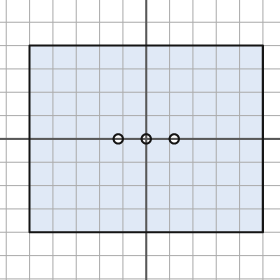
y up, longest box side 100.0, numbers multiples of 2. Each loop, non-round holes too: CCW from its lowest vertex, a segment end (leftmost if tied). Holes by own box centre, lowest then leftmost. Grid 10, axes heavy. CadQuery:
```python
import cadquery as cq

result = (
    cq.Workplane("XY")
    .moveTo(-50.0, -40.0)
    .lineTo(50.0, -40.0)
    .lineTo(50.0, 40.0)
    .lineTo(-50.0, 40.0)
    .close()
    .moveTo(-12.0, 0.0)
    .circle(2.0)
    .moveTo(0.0, 0.0)
    .circle(2.0)
    .moveTo(12.0, 0.0)
    .circle(2.0)
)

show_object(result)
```